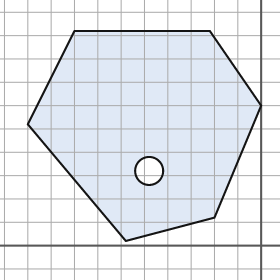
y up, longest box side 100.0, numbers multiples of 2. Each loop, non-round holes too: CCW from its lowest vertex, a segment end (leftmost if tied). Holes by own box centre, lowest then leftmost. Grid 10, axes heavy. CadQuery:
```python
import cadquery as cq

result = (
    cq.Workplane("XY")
    .moveTo(-58.0, 2.0)
    .lineTo(-20.0, 12.0)
    .lineTo(0.0, 60.0)
    .lineTo(-22.0, 92.0)
    .lineTo(-80.0, 92.0)
    .lineTo(-100.0, 52.0)
    .close()
    .moveTo(-48.0, 32.0)
    .circle(6.0)
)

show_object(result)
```